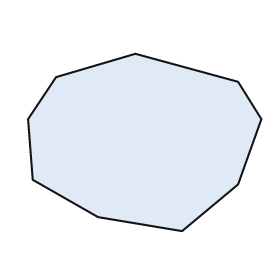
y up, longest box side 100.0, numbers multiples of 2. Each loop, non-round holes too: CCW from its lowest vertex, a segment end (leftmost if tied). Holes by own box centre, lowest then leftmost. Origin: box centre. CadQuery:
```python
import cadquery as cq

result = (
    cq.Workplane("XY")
    .moveTo(16.0, -38.0)
    .lineTo(40.0, -18.0)
    .lineTo(50.0, 10.0)
    .lineTo(40.0, 26.0)
    .lineTo(-4.0, 38.0)
    .lineTo(-38.0, 28.0)
    .lineTo(-50.0, 10.0)
    .lineTo(-48.0, -16.0)
    .lineTo(-20.0, -32.0)
    .close()
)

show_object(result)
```